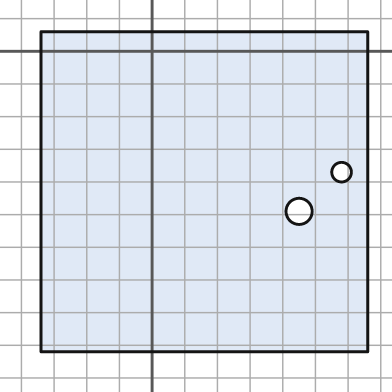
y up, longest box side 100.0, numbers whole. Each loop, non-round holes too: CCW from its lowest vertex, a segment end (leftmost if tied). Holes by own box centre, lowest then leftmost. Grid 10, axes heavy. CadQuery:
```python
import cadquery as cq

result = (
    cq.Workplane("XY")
    .moveTo(-34.0, -92.0)
    .lineTo(66.0, -92.0)
    .lineTo(66.0, 6.0)
    .lineTo(-34.0, 6.0)
    .close()
    .moveTo(45.0, -49.0)
    .circle(4.0)
    .moveTo(58.0, -37.0)
    .circle(3.0)
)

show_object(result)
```